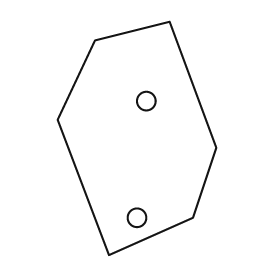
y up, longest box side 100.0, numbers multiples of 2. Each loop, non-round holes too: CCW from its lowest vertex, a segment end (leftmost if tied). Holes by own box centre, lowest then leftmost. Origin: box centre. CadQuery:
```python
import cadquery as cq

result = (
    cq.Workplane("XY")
    .moveTo(-12.0, -50.0)
    .lineTo(24.0, -34.0)
    .lineTo(34.0, -4.0)
    .lineTo(14.0, 50.0)
    .lineTo(-18.0, 42.0)
    .lineTo(-34.0, 8.0)
    .close()
    .moveTo(0.0, -34.0)
    .circle(4.0)
    .moveTo(4.0, 16.0)
    .circle(4.0)
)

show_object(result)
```